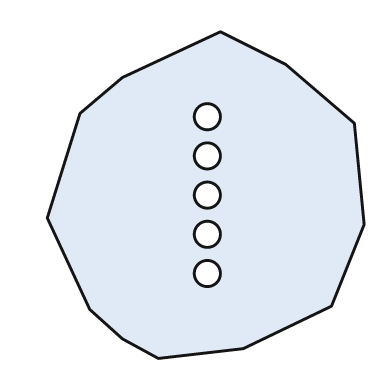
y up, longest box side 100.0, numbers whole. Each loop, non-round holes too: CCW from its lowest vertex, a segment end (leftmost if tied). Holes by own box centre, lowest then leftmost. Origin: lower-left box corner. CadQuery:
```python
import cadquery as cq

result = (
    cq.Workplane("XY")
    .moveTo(34.0, 0.0)
    .lineTo(60.0, 3.0)
    .lineTo(87.0, 16.0)
    .lineTo(97.0, 41.0)
    .lineTo(94.0, 72.0)
    .lineTo(73.0, 90.0)
    .lineTo(53.0, 100.0)
    .lineTo(23.0, 86.0)
    .lineTo(10.0, 75.0)
    .lineTo(0.0, 43.0)
    .lineTo(13.0, 15.0)
    .lineTo(23.0, 6.0)
    .close()
    .moveTo(49.0, 26.0)
    .circle(4.0)
    .moveTo(49.0, 38.0)
    .circle(4.0)
    .moveTo(49.0, 50.0)
    .circle(4.0)
    .moveTo(49.0, 62.0)
    .circle(4.0)
    .moveTo(49.0, 74.0)
    .circle(4.0)
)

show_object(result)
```